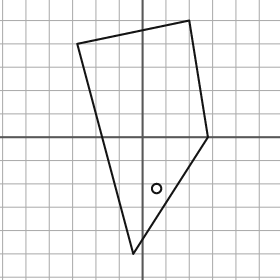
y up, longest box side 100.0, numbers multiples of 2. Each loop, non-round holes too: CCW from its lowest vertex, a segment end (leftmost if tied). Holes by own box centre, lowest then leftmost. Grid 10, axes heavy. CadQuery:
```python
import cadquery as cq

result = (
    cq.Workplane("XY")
    .moveTo(-4.0, -50.0)
    .lineTo(28.0, 0.0)
    .lineTo(20.0, 50.0)
    .lineTo(-28.0, 40.0)
    .close()
    .moveTo(6.0, -22.0)
    .circle(2.0)
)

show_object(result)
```